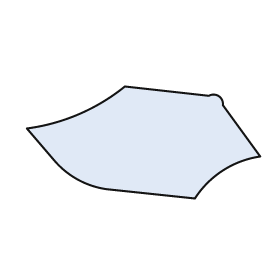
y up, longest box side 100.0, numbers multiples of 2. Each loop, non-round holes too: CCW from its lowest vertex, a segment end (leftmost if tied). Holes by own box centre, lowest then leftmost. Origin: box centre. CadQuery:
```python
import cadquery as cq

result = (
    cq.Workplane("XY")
    .moveTo(22.0, -24.0)
    .threePointArc((34.0, -12.0), (50.0, -6.0))
    .lineTo(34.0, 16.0)
    .threePointArc((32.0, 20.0), (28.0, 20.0))
    .lineTo(-8.0, 24.0)
    .threePointArc((-28.0, 12.0), (-50.0, 6.0))
    .lineTo(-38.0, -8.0)
    .threePointArc((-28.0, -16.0), (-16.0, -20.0))
    .close()
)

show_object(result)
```